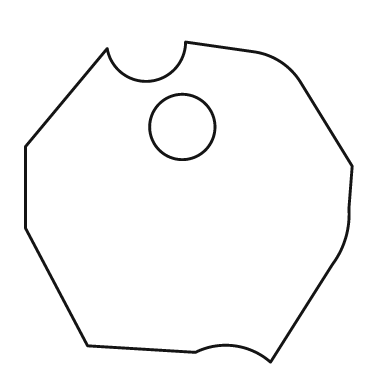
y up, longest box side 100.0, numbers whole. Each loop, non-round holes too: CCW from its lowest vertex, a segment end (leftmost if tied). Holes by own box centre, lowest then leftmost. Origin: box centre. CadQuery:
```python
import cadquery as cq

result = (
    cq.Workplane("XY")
    .moveTo(25.0, -49.0)
    .lineTo(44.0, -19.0)
    .threePointArc((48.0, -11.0), (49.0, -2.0))
    .lineTo(50.0, 11.0)
    .lineTo(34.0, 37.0)
    .threePointArc((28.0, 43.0), (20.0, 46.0))
    .lineTo(-1.0, 49.0)
    .threePointArc((-12.0, 37.0), (-25.0, 47.0))
    .lineTo(-50.0, 17.0)
    .lineTo(-50.0, -8.0)
    .lineTo(-31.0, -44.0)
    .lineTo(2.0, -46.0)
    .threePointArc((14.0, -44.0), (25.0, -49.0))
    .close()
    .moveTo(-2.0, 23.0)
    .circle(10.0)
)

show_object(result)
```